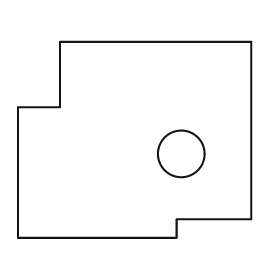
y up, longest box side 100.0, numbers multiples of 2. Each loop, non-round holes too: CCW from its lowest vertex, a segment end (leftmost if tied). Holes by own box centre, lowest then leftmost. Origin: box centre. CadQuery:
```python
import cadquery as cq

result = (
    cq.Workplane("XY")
    .moveTo(-50.0, -42.0)
    .lineTo(18.0, -42.0)
    .lineTo(18.0, -34.0)
    .lineTo(50.0, -34.0)
    .lineTo(50.0, 42.0)
    .lineTo(-32.0, 42.0)
    .lineTo(-32.0, 14.0)
    .lineTo(-50.0, 14.0)
    .close()
    .moveTo(20.0, -6.0)
    .circle(10.0)
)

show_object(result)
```